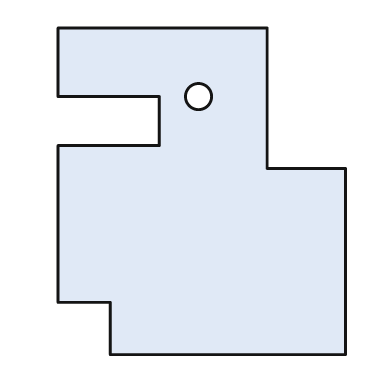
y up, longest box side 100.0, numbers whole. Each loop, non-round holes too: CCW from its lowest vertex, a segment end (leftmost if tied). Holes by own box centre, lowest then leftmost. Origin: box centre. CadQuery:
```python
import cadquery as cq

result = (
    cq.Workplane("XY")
    .moveTo(-28.0, -50.0)
    .lineTo(44.0, -50.0)
    .lineTo(44.0, 7.0)
    .lineTo(20.0, 7.0)
    .lineTo(20.0, 50.0)
    .lineTo(-44.0, 50.0)
    .lineTo(-44.0, 29.0)
    .lineTo(-13.0, 29.0)
    .lineTo(-13.0, 14.0)
    .lineTo(-44.0, 14.0)
    .lineTo(-44.0, -34.0)
    .lineTo(-28.0, -34.0)
    .close()
    .moveTo(-1.0, 29.0)
    .circle(4.0)
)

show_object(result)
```